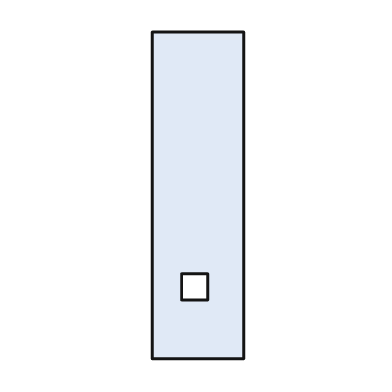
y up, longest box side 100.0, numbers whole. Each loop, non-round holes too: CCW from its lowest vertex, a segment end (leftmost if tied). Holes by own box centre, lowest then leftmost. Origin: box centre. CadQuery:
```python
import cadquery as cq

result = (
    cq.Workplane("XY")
    .moveTo(-14.0, -50.0)
    .lineTo(14.0, -50.0)
    .lineTo(14.0, 50.0)
    .lineTo(-14.0, 50.0)
    .close()
    .moveTo(-5.0, -32.0)
    .lineTo(3.0, -32.0)
    .lineTo(3.0, -24.0)
    .lineTo(-5.0, -24.0)
    .close()
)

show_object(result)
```